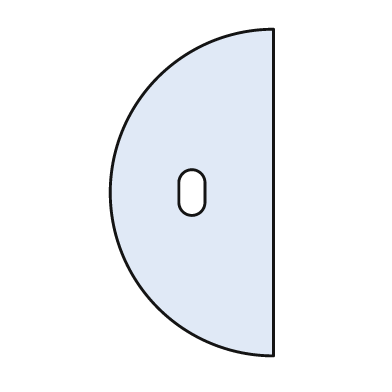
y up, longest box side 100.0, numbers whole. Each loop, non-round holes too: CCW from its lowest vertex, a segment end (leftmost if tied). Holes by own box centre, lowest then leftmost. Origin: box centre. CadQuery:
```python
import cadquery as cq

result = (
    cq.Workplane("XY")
    .moveTo(25.0, -50.0)
    .lineTo(25.0, 50.0)
    .threePointArc((-25.0, 0.0), (25.0, -50.0))
    .close()
    .moveTo(-4.0, -3.0)
    .threePointArc((0.0, -7.0), (4.0, -3.0))
    .lineTo(4.0, 3.0)
    .threePointArc((0.0, 7.0), (-4.0, 3.0))
    .close()
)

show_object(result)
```